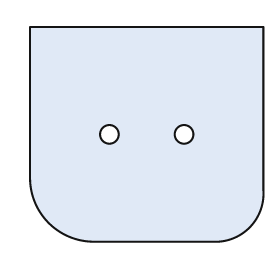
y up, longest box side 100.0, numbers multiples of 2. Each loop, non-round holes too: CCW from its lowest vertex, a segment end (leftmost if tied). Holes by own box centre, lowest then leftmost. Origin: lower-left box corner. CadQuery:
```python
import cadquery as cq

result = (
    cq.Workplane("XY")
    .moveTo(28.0, 0.0)
    .lineTo(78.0, 0.0)
    .threePointArc((94.0, 6.0), (100.0, 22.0))
    .lineTo(100.0, 92.0)
    .lineTo(0.0, 92.0)
    .lineTo(0.0, 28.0)
    .threePointArc((8.0, 8.0), (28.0, 0.0))
    .close()
    .moveTo(34.0, 46.0)
    .circle(4.0)
    .moveTo(66.0, 46.0)
    .circle(4.0)
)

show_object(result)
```